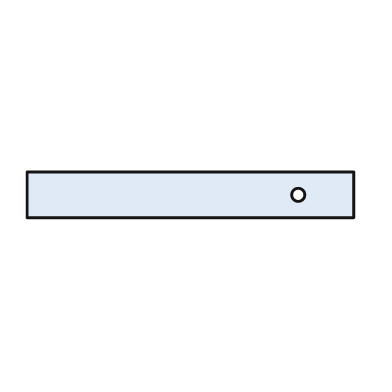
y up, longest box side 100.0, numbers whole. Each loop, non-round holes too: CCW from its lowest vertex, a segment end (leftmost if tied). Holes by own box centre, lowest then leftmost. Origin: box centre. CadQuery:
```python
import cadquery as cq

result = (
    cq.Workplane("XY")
    .moveTo(-50.0, -7.0)
    .lineTo(50.0, -7.0)
    .lineTo(50.0, 7.0)
    .lineTo(-50.0, 7.0)
    .close()
    .moveTo(33.0, 0.0)
    .circle(2.0)
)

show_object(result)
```